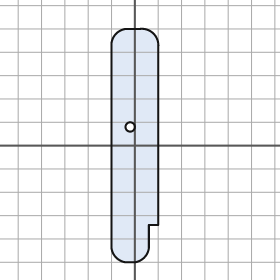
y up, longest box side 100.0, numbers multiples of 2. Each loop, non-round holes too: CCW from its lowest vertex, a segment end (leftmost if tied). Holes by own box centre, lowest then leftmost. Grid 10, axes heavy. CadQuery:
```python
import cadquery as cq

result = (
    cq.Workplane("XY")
    .moveTo(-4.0, -50.0)
    .lineTo(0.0, -50.0)
    .threePointArc((4.0, -48.0), (6.0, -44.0))
    .lineTo(6.0, -34.0)
    .lineTo(10.0, -34.0)
    .lineTo(10.0, 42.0)
    .threePointArc((8.0, 48.0), (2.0, 50.0))
    .lineTo(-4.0, 50.0)
    .threePointArc((-8.0, 48.0), (-10.0, 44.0))
    .lineTo(-10.0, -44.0)
    .threePointArc((-8.0, -48.0), (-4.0, -50.0))
    .close()
    .moveTo(-2.0, 8.0)
    .circle(2.0)
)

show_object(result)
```